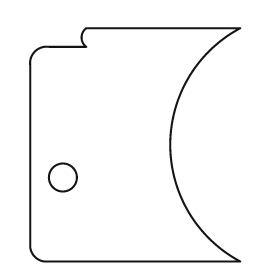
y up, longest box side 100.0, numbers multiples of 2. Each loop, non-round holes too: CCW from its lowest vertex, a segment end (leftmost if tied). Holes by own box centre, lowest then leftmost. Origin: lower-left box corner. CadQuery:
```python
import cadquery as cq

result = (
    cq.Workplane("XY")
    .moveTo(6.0, 0.0)
    .lineTo(90.0, 0.0)
    .threePointArc((60.0, 50.0), (90.0, 100.0))
    .lineTo(24.0, 100.0)
    .threePointArc((22.0, 96.0), (24.0, 92.0))
    .lineTo(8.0, 92.0)
    .threePointArc((2.0, 90.0), (0.0, 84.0))
    .lineTo(0.0, 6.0)
    .threePointArc((2.0, 2.0), (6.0, 0.0))
    .close()
    .moveTo(14.0, 36.0)
    .circle(6.0)
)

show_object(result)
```